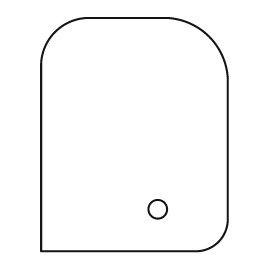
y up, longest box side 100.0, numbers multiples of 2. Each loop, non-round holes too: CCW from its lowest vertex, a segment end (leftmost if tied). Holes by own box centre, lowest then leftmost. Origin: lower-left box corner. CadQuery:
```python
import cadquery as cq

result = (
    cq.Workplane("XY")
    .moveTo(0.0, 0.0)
    .lineTo(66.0, 0.0)
    .threePointArc((76.0, 4.0), (80.0, 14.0))
    .lineTo(80.0, 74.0)
    .threePointArc((72.0, 92.0), (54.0, 100.0))
    .lineTo(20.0, 100.0)
    .threePointArc((6.0, 94.0), (0.0, 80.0))
    .close()
    .moveTo(50.0, 18.0)
    .circle(4.0)
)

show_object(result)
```